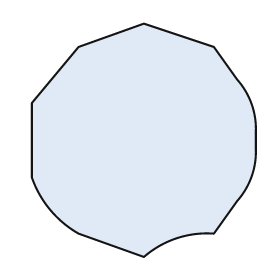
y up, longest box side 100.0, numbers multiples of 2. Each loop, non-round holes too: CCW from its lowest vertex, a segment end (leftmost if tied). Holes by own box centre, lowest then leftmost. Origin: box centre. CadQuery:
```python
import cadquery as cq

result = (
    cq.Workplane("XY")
    .moveTo(0.0, -50.0)
    .threePointArc((14.0, -42.0), (30.0, -40.0))
    .lineTo(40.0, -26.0)
    .threePointArc((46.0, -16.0), (48.0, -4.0))
    .lineTo(48.0, 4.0)
    .threePointArc((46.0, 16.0), (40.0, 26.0))
    .lineTo(30.0, 40.0)
    .lineTo(0.0, 50.0)
    .lineTo(-28.0, 40.0)
    .lineTo(-48.0, 16.0)
    .lineTo(-48.0, -16.0)
    .threePointArc((-40.0, -30.0), (-28.0, -40.0))
    .close()
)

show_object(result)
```